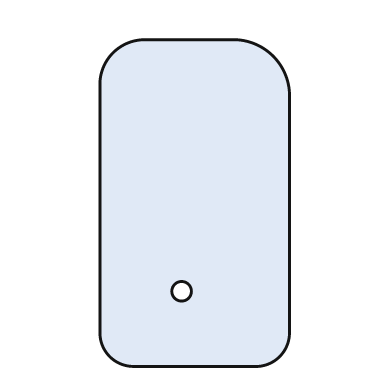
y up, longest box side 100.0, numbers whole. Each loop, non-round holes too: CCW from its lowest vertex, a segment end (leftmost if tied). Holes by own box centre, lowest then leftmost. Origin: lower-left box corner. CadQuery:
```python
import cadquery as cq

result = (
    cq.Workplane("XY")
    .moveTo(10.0, 0.0)
    .lineTo(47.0, 0.0)
    .threePointArc((55.0, 3.0), (58.0, 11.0))
    .lineTo(58.0, 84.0)
    .threePointArc((53.0, 95.0), (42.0, 100.0))
    .lineTo(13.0, 100.0)
    .threePointArc((4.0, 96.0), (0.0, 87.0))
    .lineTo(0.0, 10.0)
    .threePointArc((3.0, 3.0), (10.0, 0.0))
    .close()
    .moveTo(25.0, 23.0)
    .circle(3.0)
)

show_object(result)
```